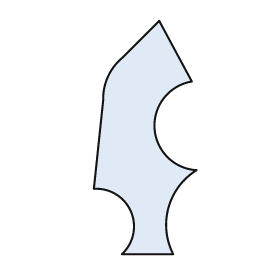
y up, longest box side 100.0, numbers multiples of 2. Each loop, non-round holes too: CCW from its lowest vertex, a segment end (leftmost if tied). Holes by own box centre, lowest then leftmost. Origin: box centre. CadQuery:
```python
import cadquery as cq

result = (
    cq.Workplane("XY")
    .moveTo(-10.0, -50.0)
    .lineTo(12.0, -50.0)
    .threePointArc((10.0, -30.0), (22.0, -14.0))
    .threePointArc((4.0, 4.0), (20.0, 24.0))
    .lineTo(6.0, 50.0)
    .lineTo(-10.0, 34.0)
    .threePointArc((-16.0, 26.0), (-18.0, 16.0))
    .lineTo(-22.0, -22.0)
    .threePointArc((-6.0, -32.0), (-10.0, -50.0))
    .close()
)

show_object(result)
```